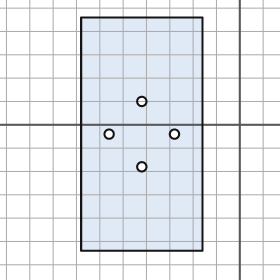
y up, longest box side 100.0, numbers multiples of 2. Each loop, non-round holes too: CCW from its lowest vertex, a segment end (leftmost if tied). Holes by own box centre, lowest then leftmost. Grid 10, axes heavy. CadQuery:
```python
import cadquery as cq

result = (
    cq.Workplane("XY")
    .moveTo(-68.0, -54.0)
    .lineTo(-16.0, -54.0)
    .lineTo(-16.0, 46.0)
    .lineTo(-68.0, 46.0)
    .close()
    .moveTo(-42.0, -18.0)
    .circle(2.0)
    .moveTo(-56.0, -4.0)
    .circle(2.0)
    .moveTo(-28.0, -4.0)
    .circle(2.0)
    .moveTo(-42.0, 10.0)
    .circle(2.0)
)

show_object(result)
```